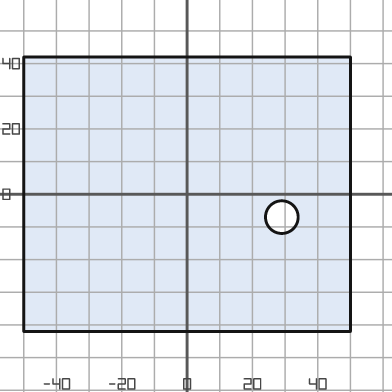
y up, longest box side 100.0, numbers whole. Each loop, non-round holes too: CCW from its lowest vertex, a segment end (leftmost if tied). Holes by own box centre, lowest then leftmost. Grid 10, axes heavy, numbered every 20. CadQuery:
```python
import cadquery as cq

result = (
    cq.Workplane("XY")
    .moveTo(-50.0, -42.0)
    .lineTo(50.0, -42.0)
    .lineTo(50.0, 42.0)
    .lineTo(-50.0, 42.0)
    .close()
    .moveTo(29.0, -7.0)
    .circle(5.0)
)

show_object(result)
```